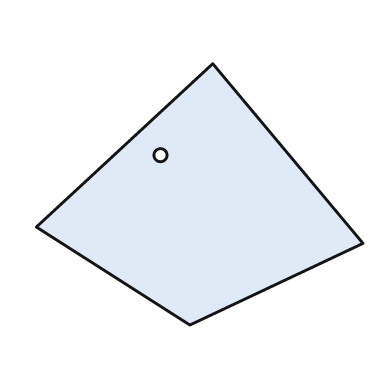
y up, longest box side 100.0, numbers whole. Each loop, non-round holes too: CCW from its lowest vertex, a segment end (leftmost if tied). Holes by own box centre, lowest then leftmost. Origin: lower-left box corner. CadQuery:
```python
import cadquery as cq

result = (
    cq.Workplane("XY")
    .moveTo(47.0, 0.0)
    .lineTo(100.0, 25.0)
    .lineTo(54.0, 80.0)
    .lineTo(0.0, 30.0)
    .close()
    .moveTo(38.0, 52.0)
    .circle(2.0)
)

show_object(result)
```